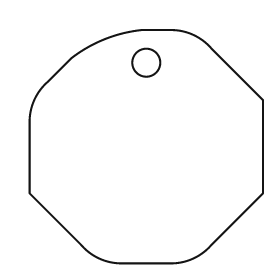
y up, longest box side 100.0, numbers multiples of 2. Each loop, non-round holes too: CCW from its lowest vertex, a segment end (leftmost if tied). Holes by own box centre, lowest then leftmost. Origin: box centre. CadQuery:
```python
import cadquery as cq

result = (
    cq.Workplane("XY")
    .moveTo(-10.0, -50.0)
    .lineTo(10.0, -50.0)
    .threePointArc((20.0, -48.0), (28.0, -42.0))
    .lineTo(50.0, -20.0)
    .lineTo(50.0, 20.0)
    .lineTo(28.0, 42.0)
    .threePointArc((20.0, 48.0), (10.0, 50.0))
    .lineTo(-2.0, 50.0)
    .threePointArc((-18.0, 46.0), (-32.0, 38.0))
    .lineTo(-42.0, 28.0)
    .threePointArc((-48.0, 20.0), (-50.0, 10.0))
    .lineTo(-50.0, -20.0)
    .lineTo(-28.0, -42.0)
    .threePointArc((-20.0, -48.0), (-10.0, -50.0))
    .close()
    .moveTo(0.0, 36.0)
    .circle(6.0)
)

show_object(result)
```